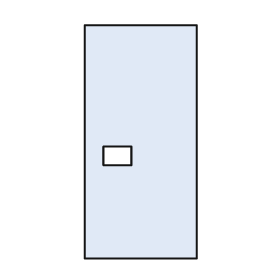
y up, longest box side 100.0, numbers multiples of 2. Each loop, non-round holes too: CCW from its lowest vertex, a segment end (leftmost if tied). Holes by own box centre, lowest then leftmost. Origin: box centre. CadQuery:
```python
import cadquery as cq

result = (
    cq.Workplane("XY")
    .moveTo(-24.0, -50.0)
    .lineTo(24.0, -50.0)
    .lineTo(24.0, 50.0)
    .lineTo(-24.0, 50.0)
    .close()
    .moveTo(-16.0, -10.0)
    .lineTo(-4.0, -10.0)
    .lineTo(-4.0, -2.0)
    .lineTo(-16.0, -2.0)
    .close()
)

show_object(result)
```